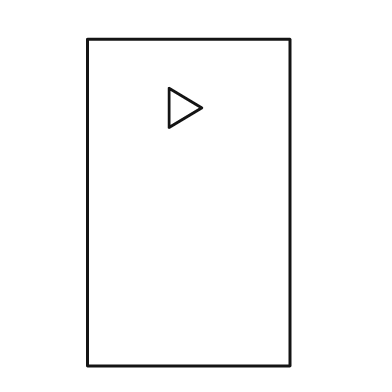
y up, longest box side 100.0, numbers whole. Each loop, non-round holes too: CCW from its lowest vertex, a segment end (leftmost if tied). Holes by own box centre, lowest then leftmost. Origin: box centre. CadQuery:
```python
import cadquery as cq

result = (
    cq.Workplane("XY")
    .moveTo(-31.0, -50.0)
    .lineTo(31.0, -50.0)
    .lineTo(31.0, 50.0)
    .lineTo(-31.0, 50.0)
    .close()
    .moveTo(-6.0, 23.0)
    .lineTo(4.0, 29.0)
    .lineTo(-6.0, 35.0)
    .close()
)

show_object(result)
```